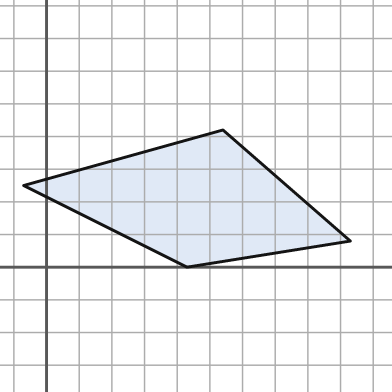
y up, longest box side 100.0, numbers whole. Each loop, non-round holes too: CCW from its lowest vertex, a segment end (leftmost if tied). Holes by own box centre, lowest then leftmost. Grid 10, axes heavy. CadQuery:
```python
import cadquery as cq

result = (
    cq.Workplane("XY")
    .moveTo(43.0, 0.0)
    .lineTo(93.0, 8.0)
    .lineTo(54.0, 42.0)
    .lineTo(-7.0, 25.0)
    .close()
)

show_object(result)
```